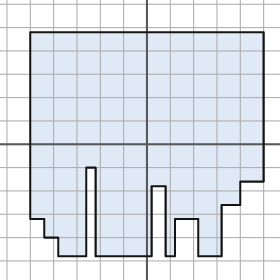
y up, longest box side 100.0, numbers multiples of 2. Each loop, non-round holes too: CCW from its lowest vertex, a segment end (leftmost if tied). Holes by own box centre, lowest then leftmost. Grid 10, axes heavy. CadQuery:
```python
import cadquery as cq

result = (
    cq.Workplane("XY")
    .moveTo(-38.0, -48.0)
    .lineTo(-26.0, -48.0)
    .lineTo(-26.0, -10.0)
    .lineTo(-22.0, -10.0)
    .lineTo(-22.0, -48.0)
    .lineTo(2.0, -48.0)
    .lineTo(2.0, -18.0)
    .lineTo(8.0, -18.0)
    .lineTo(8.0, -48.0)
    .lineTo(12.0, -48.0)
    .lineTo(12.0, -32.0)
    .lineTo(22.0, -32.0)
    .lineTo(22.0, -48.0)
    .lineTo(32.0, -48.0)
    .lineTo(32.0, -26.0)
    .lineTo(40.0, -26.0)
    .lineTo(40.0, -16.0)
    .lineTo(50.0, -16.0)
    .lineTo(50.0, 48.0)
    .lineTo(-50.0, 48.0)
    .lineTo(-50.0, -32.0)
    .lineTo(-44.0, -32.0)
    .lineTo(-44.0, -40.0)
    .lineTo(-38.0, -40.0)
    .close()
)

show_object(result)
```